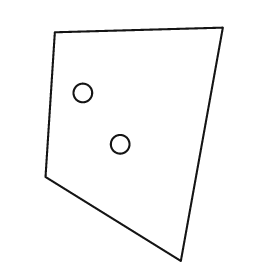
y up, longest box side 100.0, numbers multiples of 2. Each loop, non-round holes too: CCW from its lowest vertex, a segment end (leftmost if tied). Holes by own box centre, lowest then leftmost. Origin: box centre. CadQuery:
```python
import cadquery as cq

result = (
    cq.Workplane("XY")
    .moveTo(20.0, -50.0)
    .lineTo(38.0, 50.0)
    .lineTo(-34.0, 48.0)
    .lineTo(-38.0, -14.0)
    .close()
    .moveTo(-6.0, 0.0)
    .circle(4.0)
    .moveTo(-22.0, 22.0)
    .circle(4.0)
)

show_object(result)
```